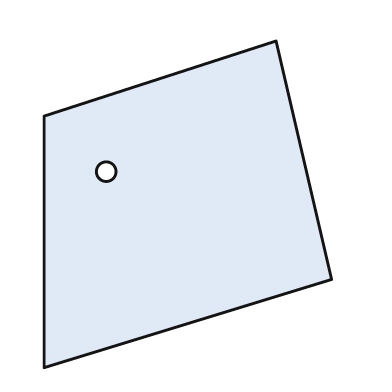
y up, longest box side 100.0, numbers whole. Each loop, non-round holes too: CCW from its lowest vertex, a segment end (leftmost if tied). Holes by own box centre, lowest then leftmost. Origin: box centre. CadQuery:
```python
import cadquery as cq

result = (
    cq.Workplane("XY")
    .moveTo(-44.0, -50.0)
    .lineTo(44.0, -23.0)
    .lineTo(27.0, 50.0)
    .lineTo(-44.0, 27.0)
    .close()
    .moveTo(-25.0, 10.0)
    .circle(3.0)
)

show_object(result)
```